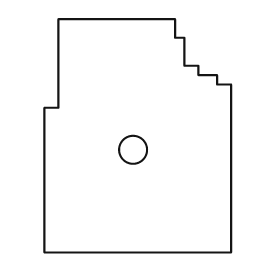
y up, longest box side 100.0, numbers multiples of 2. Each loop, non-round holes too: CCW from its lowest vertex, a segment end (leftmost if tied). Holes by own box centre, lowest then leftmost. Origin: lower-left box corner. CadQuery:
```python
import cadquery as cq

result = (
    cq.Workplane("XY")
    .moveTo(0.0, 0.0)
    .lineTo(80.0, 0.0)
    .lineTo(80.0, 72.0)
    .lineTo(74.0, 72.0)
    .lineTo(74.0, 76.0)
    .lineTo(66.0, 76.0)
    .lineTo(66.0, 80.0)
    .lineTo(60.0, 80.0)
    .lineTo(60.0, 92.0)
    .lineTo(56.0, 92.0)
    .lineTo(56.0, 100.0)
    .lineTo(6.0, 100.0)
    .lineTo(6.0, 62.0)
    .lineTo(0.0, 62.0)
    .close()
    .moveTo(38.0, 44.0)
    .circle(6.0)
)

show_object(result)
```